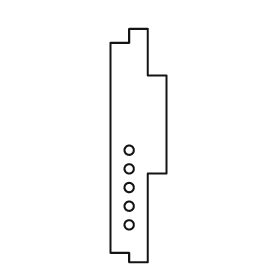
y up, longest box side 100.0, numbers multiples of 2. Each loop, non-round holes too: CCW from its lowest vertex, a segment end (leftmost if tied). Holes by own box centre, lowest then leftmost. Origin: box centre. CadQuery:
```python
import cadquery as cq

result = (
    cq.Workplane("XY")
    .moveTo(-4.0, -50.0)
    .lineTo(4.0, -50.0)
    .lineTo(4.0, -12.0)
    .lineTo(12.0, -12.0)
    .lineTo(12.0, 30.0)
    .lineTo(4.0, 30.0)
    .lineTo(4.0, 50.0)
    .lineTo(-4.0, 50.0)
    .lineTo(-4.0, 44.0)
    .lineTo(-12.0, 44.0)
    .lineTo(-12.0, -46.0)
    .lineTo(-4.0, -46.0)
    .close()
    .moveTo(-4.0, -34.0)
    .circle(2.0)
    .moveTo(-4.0, -26.0)
    .circle(2.0)
    .moveTo(-4.0, -18.0)
    .circle(2.0)
    .moveTo(-4.0, -10.0)
    .circle(2.0)
    .moveTo(-4.0, -2.0)
    .circle(2.0)
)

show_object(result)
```